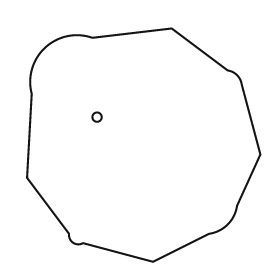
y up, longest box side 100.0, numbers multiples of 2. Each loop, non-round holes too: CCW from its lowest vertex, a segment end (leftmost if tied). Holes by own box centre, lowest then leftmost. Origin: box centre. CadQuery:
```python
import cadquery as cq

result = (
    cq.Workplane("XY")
    .moveTo(4.0, -50.0)
    .lineTo(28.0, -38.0)
    .threePointArc((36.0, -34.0), (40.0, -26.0))
    .lineTo(50.0, -4.0)
    .lineTo(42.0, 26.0)
    .threePointArc((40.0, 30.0), (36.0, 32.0))
    .lineTo(12.0, 50.0)
    .lineTo(-22.0, 46.0)
    .threePointArc((-42.0, 42.0), (-48.0, 22.0))
    .lineTo(-50.0, -14.0)
    .lineTo(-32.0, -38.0)
    .threePointArc((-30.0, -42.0), (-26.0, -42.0))
    .close()
    .moveTo(-20.0, 12.0)
    .circle(2.0)
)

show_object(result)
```